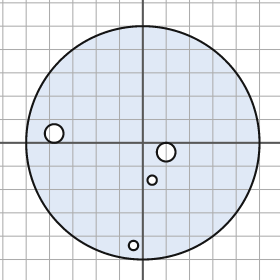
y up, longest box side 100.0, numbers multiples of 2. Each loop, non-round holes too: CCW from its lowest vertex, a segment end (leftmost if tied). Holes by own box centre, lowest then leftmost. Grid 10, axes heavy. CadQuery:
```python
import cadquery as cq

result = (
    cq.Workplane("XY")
    .moveTo(0.0, 0.0)
    .circle(50.0)
    .moveTo(-4.0, -44.0)
    .circle(2.0)
    .moveTo(4.0, -16.0)
    .circle(2.0)
    .moveTo(10.0, -4.0)
    .circle(4.0)
    .moveTo(-38.0, 4.0)
    .circle(4.0)
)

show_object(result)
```